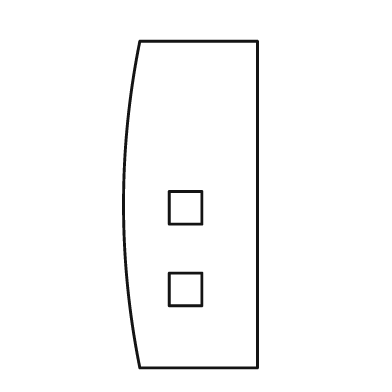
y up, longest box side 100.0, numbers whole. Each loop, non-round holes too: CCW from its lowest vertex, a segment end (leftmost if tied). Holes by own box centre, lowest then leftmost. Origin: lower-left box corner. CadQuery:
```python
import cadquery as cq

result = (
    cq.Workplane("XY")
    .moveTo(5.0, 0.0)
    .lineTo(41.0, 0.0)
    .lineTo(41.0, 100.0)
    .lineTo(5.0, 100.0)
    .threePointArc((0.0, 50.0), (5.0, 0.0))
    .close()
    .moveTo(14.0, 19.0)
    .lineTo(24.0, 19.0)
    .lineTo(24.0, 29.0)
    .lineTo(14.0, 29.0)
    .close()
    .moveTo(14.0, 44.0)
    .lineTo(24.0, 44.0)
    .lineTo(24.0, 54.0)
    .lineTo(14.0, 54.0)
    .close()
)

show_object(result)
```